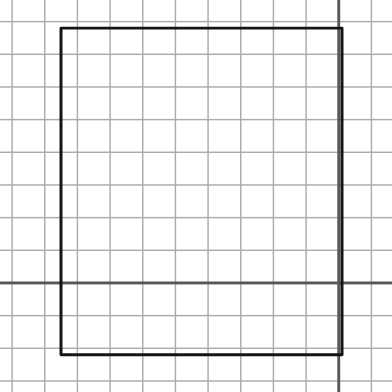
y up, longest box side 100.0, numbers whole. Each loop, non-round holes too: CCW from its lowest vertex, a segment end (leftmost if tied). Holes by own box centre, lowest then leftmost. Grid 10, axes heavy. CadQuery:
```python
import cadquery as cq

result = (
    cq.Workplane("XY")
    .moveTo(-85.0, -22.0)
    .lineTo(1.0, -22.0)
    .lineTo(1.0, 78.0)
    .lineTo(-85.0, 78.0)
    .close()
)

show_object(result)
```